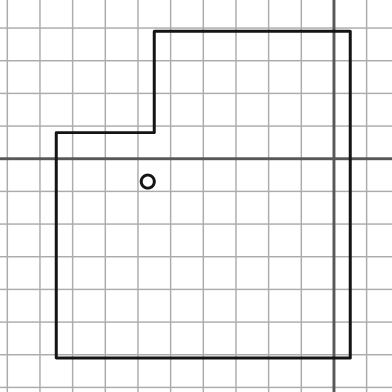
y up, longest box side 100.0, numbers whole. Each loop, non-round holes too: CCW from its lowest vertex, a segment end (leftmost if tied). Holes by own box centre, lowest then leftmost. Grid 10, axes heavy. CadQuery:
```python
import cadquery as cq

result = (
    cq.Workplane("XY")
    .moveTo(-85.0, -61.0)
    .lineTo(5.0, -61.0)
    .lineTo(5.0, 39.0)
    .lineTo(-55.0, 39.0)
    .lineTo(-55.0, 8.0)
    .lineTo(-85.0, 8.0)
    .close()
    .moveTo(-57.0, -7.0)
    .circle(2.0)
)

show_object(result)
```